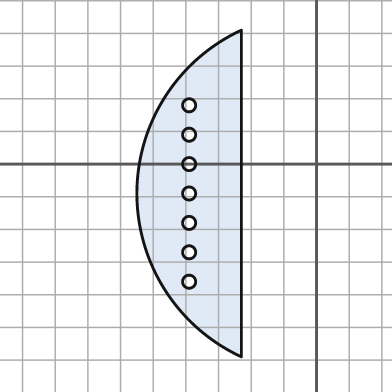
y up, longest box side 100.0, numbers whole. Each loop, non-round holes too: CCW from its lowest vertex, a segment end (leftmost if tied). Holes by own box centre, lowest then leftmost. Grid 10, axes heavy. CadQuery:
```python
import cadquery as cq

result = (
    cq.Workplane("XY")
    .moveTo(-23.0, -59.0)
    .lineTo(-23.0, 41.0)
    .threePointArc((-55.0, -9.0), (-23.0, -59.0))
    .close()
    .moveTo(-39.0, -36.0)
    .circle(2.0)
    .moveTo(-39.0, -27.0)
    .circle(2.0)
    .moveTo(-39.0, -18.0)
    .circle(2.0)
    .moveTo(-39.0, -9.0)
    .circle(2.0)
    .moveTo(-39.0, 0.0)
    .circle(2.0)
    .moveTo(-39.0, 9.0)
    .circle(2.0)
    .moveTo(-39.0, 18.0)
    .circle(2.0)
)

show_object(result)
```